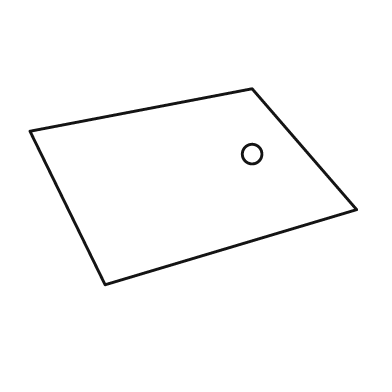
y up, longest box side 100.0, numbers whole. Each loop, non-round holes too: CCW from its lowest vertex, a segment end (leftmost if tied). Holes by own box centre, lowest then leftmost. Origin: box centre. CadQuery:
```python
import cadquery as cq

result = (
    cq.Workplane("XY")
    .moveTo(-27.0, -30.0)
    .lineTo(50.0, -7.0)
    .lineTo(18.0, 30.0)
    .lineTo(-50.0, 17.0)
    .close()
    .moveTo(18.0, 10.0)
    .circle(3.0)
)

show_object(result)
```